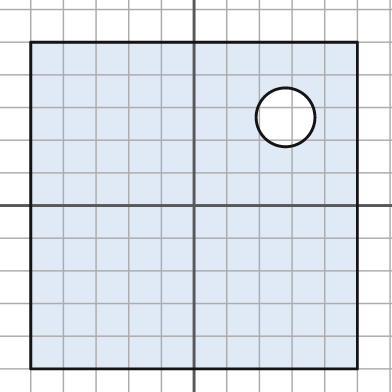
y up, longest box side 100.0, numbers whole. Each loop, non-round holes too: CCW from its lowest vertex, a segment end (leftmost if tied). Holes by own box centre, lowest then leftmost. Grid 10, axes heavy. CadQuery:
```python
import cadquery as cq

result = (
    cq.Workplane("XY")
    .moveTo(-50.0, -50.0)
    .lineTo(50.0, -50.0)
    .lineTo(50.0, 50.0)
    .lineTo(-50.0, 50.0)
    .close()
    .moveTo(28.0, 27.0)
    .circle(9.0)
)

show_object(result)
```